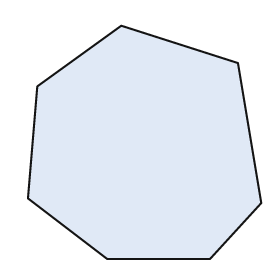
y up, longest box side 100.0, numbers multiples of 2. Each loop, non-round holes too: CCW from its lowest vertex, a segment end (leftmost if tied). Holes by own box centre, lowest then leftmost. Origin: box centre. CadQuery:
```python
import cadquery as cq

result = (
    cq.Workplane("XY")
    .moveTo(-16.0, -50.0)
    .lineTo(28.0, -50.0)
    .lineTo(50.0, -26.0)
    .lineTo(40.0, 34.0)
    .lineTo(-10.0, 50.0)
    .lineTo(-46.0, 24.0)
    .lineTo(-50.0, -24.0)
    .close()
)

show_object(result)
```